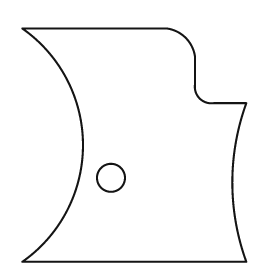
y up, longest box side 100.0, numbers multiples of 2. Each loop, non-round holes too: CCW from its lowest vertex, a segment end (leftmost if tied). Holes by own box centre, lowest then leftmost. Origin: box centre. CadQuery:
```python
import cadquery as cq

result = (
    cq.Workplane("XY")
    .moveTo(-48.0, -50.0)
    .lineTo(48.0, -50.0)
    .threePointArc((42.0, -16.0), (48.0, 18.0))
    .lineTo(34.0, 18.0)
    .threePointArc((28.0, 20.0), (26.0, 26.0))
    .lineTo(26.0, 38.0)
    .threePointArc((22.0, 46.0), (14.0, 50.0))
    .lineTo(-48.0, 50.0)
    .threePointArc((-22.0, 0.0), (-48.0, -50.0))
    .close()
    .moveTo(-10.0, -14.0)
    .circle(6.0)
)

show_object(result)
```